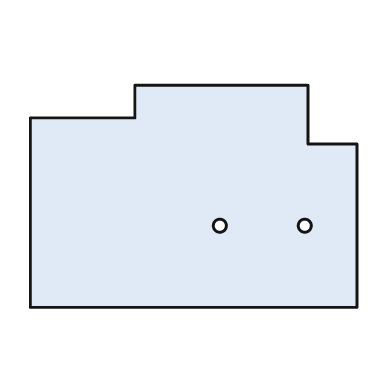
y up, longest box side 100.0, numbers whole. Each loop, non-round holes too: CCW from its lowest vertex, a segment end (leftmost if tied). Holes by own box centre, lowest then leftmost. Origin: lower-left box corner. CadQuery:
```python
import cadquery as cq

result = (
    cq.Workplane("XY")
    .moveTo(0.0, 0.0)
    .lineTo(100.0, 0.0)
    .lineTo(100.0, 50.0)
    .lineTo(85.0, 50.0)
    .lineTo(85.0, 68.0)
    .lineTo(32.0, 68.0)
    .lineTo(32.0, 58.0)
    .lineTo(0.0, 58.0)
    .close()
    .moveTo(58.0, 25.0)
    .circle(2.0)
    .moveTo(84.0, 25.0)
    .circle(2.0)
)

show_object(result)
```